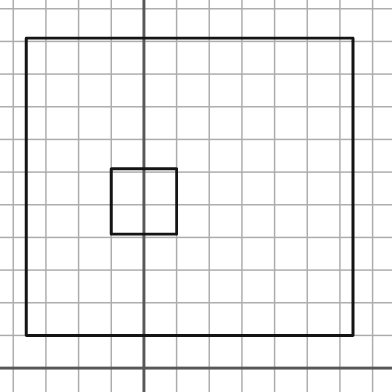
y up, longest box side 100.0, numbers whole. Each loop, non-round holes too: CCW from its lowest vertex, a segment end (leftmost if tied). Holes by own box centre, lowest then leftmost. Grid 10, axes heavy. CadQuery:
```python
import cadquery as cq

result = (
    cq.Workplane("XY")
    .moveTo(-36.0, 10.0)
    .lineTo(64.0, 10.0)
    .lineTo(64.0, 101.0)
    .lineTo(-36.0, 101.0)
    .close()
    .moveTo(-10.0, 41.0)
    .lineTo(10.0, 41.0)
    .lineTo(10.0, 61.0)
    .lineTo(-10.0, 61.0)
    .close()
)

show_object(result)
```